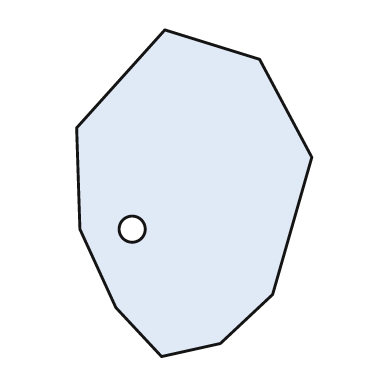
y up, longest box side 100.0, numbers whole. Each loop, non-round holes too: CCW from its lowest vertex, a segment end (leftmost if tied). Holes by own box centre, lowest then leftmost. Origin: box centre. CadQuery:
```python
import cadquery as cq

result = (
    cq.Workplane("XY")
    .moveTo(-10.0, -50.0)
    .lineTo(8.0, -46.0)
    .lineTo(24.0, -31.0)
    .lineTo(36.0, 11.0)
    .lineTo(20.0, 41.0)
    .lineTo(-9.0, 50.0)
    .lineTo(-36.0, 20.0)
    .lineTo(-35.0, -11.0)
    .lineTo(-24.0, -35.0)
    .close()
    .moveTo(-19.0, -11.0)
    .circle(4.0)
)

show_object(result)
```